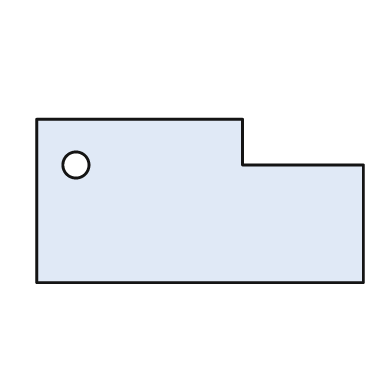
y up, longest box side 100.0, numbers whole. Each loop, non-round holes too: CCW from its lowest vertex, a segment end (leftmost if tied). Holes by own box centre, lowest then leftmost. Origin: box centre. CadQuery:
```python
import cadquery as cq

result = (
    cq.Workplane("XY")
    .moveTo(-50.0, -25.0)
    .lineTo(50.0, -25.0)
    .lineTo(50.0, 11.0)
    .lineTo(13.0, 11.0)
    .lineTo(13.0, 25.0)
    .lineTo(-50.0, 25.0)
    .close()
    .moveTo(-38.0, 11.0)
    .circle(4.0)
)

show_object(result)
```